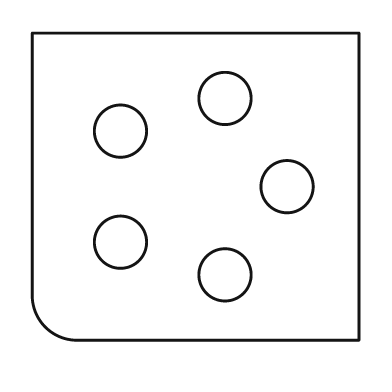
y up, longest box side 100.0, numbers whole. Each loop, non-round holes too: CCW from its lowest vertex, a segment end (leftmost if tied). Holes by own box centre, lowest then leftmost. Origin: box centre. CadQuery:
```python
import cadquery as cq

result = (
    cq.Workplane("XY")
    .moveTo(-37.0, -47.0)
    .lineTo(50.0, -47.0)
    .lineTo(50.0, 47.0)
    .lineTo(-50.0, 47.0)
    .lineTo(-50.0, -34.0)
    .threePointArc((-46.0, -43.0), (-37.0, -47.0))
    .close()
    .moveTo(9.0, -27.0)
    .circle(8.0)
    .moveTo(-23.0, -17.0)
    .circle(8.0)
    .moveTo(28.0, 0.0)
    .circle(8.0)
    .moveTo(-23.0, 17.0)
    .circle(8.0)
    .moveTo(9.0, 27.0)
    .circle(8.0)
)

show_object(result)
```